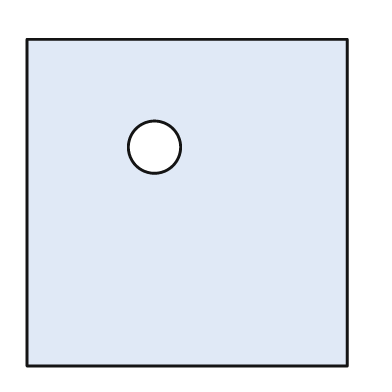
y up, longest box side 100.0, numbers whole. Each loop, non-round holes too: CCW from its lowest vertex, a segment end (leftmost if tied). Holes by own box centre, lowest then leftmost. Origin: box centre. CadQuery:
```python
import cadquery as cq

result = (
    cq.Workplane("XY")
    .moveTo(-49.0, -50.0)
    .lineTo(49.0, -50.0)
    .lineTo(49.0, 50.0)
    .lineTo(-49.0, 50.0)
    .close()
    .moveTo(-10.0, 17.0)
    .circle(8.0)
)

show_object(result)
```